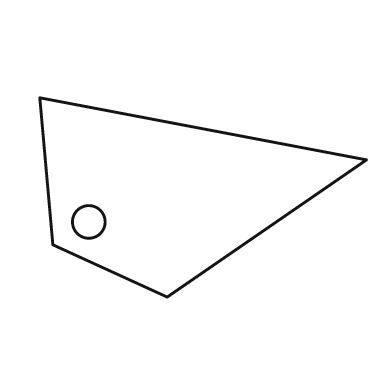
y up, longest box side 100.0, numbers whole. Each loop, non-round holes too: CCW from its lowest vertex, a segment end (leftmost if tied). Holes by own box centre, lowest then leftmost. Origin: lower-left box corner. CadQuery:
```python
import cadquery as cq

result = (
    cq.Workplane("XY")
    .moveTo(39.0, 0.0)
    .lineTo(100.0, 42.0)
    .lineTo(0.0, 61.0)
    .lineTo(4.0, 16.0)
    .close()
    .moveTo(15.0, 23.0)
    .circle(5.0)
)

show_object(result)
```